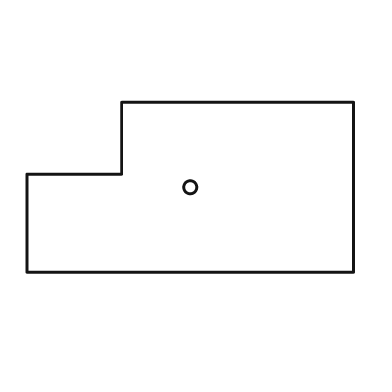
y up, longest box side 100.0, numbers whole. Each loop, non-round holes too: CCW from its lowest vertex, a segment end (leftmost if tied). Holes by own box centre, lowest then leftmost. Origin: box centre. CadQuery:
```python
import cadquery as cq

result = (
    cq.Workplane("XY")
    .moveTo(-50.0, -26.0)
    .lineTo(50.0, -26.0)
    .lineTo(50.0, 26.0)
    .lineTo(-21.0, 26.0)
    .lineTo(-21.0, 4.0)
    .lineTo(-50.0, 4.0)
    .close()
    .moveTo(0.0, 0.0)
    .circle(2.0)
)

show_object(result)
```